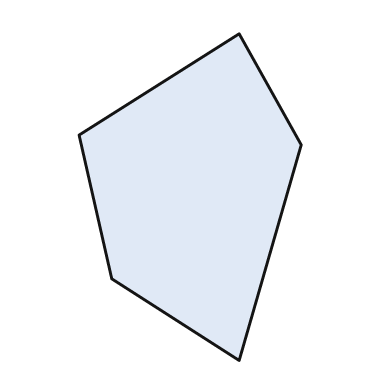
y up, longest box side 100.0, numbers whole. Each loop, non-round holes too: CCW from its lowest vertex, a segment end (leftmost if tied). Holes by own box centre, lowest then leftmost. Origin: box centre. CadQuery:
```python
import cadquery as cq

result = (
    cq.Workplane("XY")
    .moveTo(15.0, -50.0)
    .lineTo(34.0, 16.0)
    .lineTo(15.0, 50.0)
    .lineTo(-34.0, 19.0)
    .lineTo(-24.0, -25.0)
    .close()
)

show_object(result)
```